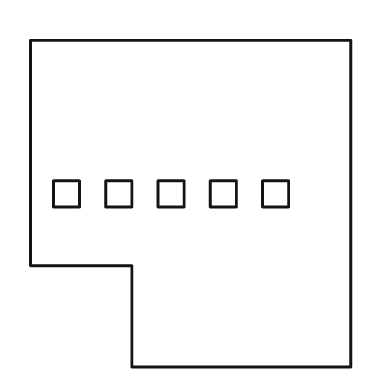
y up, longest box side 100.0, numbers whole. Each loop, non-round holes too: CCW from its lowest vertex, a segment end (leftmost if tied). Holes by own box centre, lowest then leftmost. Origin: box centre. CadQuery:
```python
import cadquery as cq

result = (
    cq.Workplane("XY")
    .moveTo(-18.0, -50.0)
    .lineTo(49.0, -50.0)
    .lineTo(49.0, 50.0)
    .lineTo(-49.0, 50.0)
    .lineTo(-49.0, -19.0)
    .lineTo(-18.0, -19.0)
    .close()
    .moveTo(-42.0, -1.0)
    .lineTo(-34.0, -1.0)
    .lineTo(-34.0, 7.0)
    .lineTo(-42.0, 7.0)
    .close()
    .moveTo(-26.0, -1.0)
    .lineTo(-18.0, -1.0)
    .lineTo(-18.0, 7.0)
    .lineTo(-26.0, 7.0)
    .close()
    .moveTo(-10.0, -1.0)
    .lineTo(-2.0, -1.0)
    .lineTo(-2.0, 7.0)
    .lineTo(-10.0, 7.0)
    .close()
    .moveTo(6.0, -1.0)
    .lineTo(14.0, -1.0)
    .lineTo(14.0, 7.0)
    .lineTo(6.0, 7.0)
    .close()
    .moveTo(22.0, -1.0)
    .lineTo(30.0, -1.0)
    .lineTo(30.0, 7.0)
    .lineTo(22.0, 7.0)
    .close()
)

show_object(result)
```